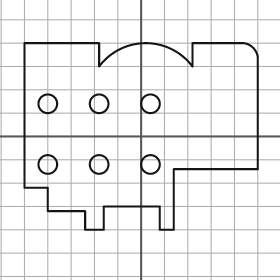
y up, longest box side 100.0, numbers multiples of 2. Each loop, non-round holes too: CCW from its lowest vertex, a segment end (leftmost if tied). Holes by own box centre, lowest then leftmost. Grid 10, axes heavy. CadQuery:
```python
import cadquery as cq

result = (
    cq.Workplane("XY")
    .moveTo(-24.0, -40.0)
    .lineTo(-16.0, -40.0)
    .lineTo(-16.0, -30.0)
    .lineTo(8.0, -30.0)
    .lineTo(8.0, -40.0)
    .lineTo(14.0, -40.0)
    .lineTo(14.0, -14.0)
    .lineTo(50.0, -14.0)
    .lineTo(50.0, 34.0)
    .threePointArc((48.0, 38.0), (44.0, 40.0))
    .lineTo(22.0, 40.0)
    .lineTo(22.0, 30.0)
    .threePointArc((2.0, 40.0), (-18.0, 30.0))
    .lineTo(-18.0, 40.0)
    .lineTo(-50.0, 40.0)
    .lineTo(-50.0, -22.0)
    .lineTo(-40.0, -22.0)
    .lineTo(-40.0, -32.0)
    .lineTo(-24.0, -32.0)
    .close()
    .moveTo(-40.0, -12.0)
    .circle(4.0)
    .moveTo(-18.0, -12.0)
    .circle(4.0)
    .moveTo(4.0, -12.0)
    .circle(4.0)
    .moveTo(-40.0, 14.0)
    .circle(4.0)
    .moveTo(-18.0, 14.0)
    .circle(4.0)
    .moveTo(4.0, 14.0)
    .circle(4.0)
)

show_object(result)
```